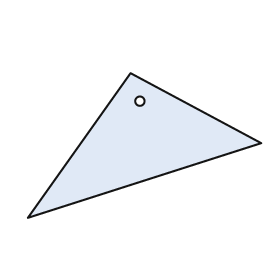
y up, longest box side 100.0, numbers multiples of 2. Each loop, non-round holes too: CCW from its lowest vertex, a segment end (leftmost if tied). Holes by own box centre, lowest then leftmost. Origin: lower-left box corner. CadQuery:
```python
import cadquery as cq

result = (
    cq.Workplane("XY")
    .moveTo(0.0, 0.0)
    .lineTo(100.0, 32.0)
    .lineTo(44.0, 62.0)
    .close()
    .moveTo(48.0, 50.0)
    .circle(2.0)
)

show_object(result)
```